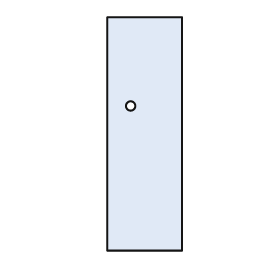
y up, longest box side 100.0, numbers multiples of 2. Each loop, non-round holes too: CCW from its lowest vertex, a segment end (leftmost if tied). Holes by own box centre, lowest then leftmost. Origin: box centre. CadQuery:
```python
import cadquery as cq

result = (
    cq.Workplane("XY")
    .moveTo(-16.0, -50.0)
    .lineTo(16.0, -50.0)
    .lineTo(16.0, 50.0)
    .lineTo(-16.0, 50.0)
    .close()
    .moveTo(-6.0, 12.0)
    .circle(2.0)
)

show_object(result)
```